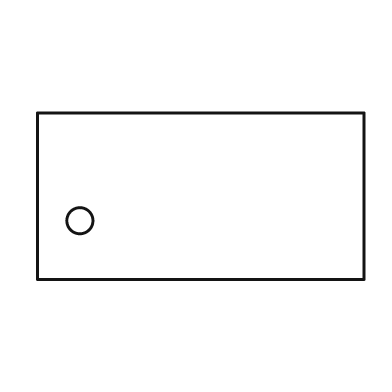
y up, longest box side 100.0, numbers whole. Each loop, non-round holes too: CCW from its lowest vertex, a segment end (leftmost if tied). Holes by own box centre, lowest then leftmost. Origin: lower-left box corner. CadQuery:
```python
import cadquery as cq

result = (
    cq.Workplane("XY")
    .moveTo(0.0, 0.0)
    .lineTo(100.0, 0.0)
    .lineTo(100.0, 51.0)
    .lineTo(0.0, 51.0)
    .close()
    .moveTo(13.0, 18.0)
    .circle(4.0)
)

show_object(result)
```